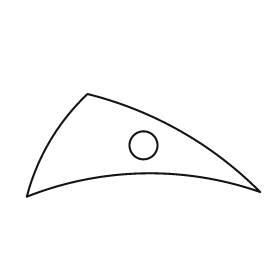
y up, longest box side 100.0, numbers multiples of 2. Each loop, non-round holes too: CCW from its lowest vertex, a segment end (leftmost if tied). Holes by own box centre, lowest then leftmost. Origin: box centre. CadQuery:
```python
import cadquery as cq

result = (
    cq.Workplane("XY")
    .moveTo(-50.0, -22.0)
    .threePointArc((0.0, -12.0), (50.0, -20.0))
    .threePointArc((16.0, 6.0), (-24.0, 22.0))
    .threePointArc((-40.0, 2.0), (-50.0, -22.0))
    .close()
    .moveTo(0.0, 0.0)
    .circle(6.0)
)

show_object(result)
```